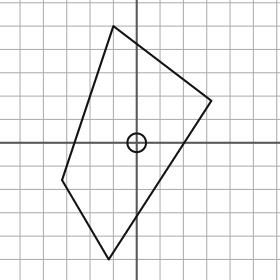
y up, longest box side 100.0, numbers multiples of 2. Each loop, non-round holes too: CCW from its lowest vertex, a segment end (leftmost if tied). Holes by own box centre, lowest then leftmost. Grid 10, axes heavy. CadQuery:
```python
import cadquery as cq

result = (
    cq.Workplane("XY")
    .moveTo(-12.0, -50.0)
    .lineTo(32.0, 18.0)
    .lineTo(-10.0, 50.0)
    .lineTo(-32.0, -16.0)
    .close()
    .moveTo(0.0, 0.0)
    .circle(4.0)
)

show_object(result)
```